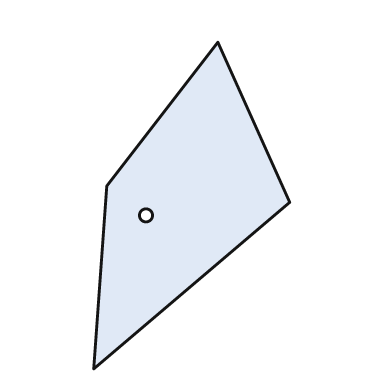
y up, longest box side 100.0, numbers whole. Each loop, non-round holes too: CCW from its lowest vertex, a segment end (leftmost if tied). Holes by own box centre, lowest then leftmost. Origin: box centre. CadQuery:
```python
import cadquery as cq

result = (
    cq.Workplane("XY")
    .moveTo(-30.0, -50.0)
    .lineTo(30.0, 1.0)
    .lineTo(8.0, 50.0)
    .lineTo(-26.0, 6.0)
    .close()
    .moveTo(-14.0, -3.0)
    .circle(2.0)
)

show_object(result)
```